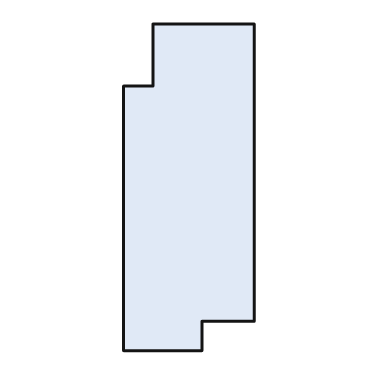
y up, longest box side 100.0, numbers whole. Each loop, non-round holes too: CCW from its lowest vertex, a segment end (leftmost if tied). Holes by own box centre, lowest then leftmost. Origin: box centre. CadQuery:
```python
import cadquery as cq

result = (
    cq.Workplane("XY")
    .moveTo(-20.0, -50.0)
    .lineTo(4.0, -50.0)
    .lineTo(4.0, -41.0)
    .lineTo(20.0, -41.0)
    .lineTo(20.0, 50.0)
    .lineTo(-11.0, 50.0)
    .lineTo(-11.0, 31.0)
    .lineTo(-20.0, 31.0)
    .close()
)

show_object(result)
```